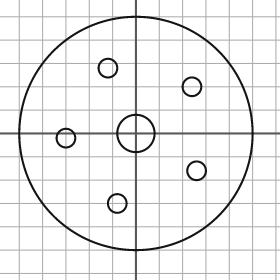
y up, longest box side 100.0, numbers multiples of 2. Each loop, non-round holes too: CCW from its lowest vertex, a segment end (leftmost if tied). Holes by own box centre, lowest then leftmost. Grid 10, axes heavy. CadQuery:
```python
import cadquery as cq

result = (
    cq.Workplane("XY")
    .moveTo(0.0, 0.0)
    .circle(50.0)
    .moveTo(-8.0, -30.0)
    .circle(4.0)
    .moveTo(26.0, -16.0)
    .circle(4.0)
    .moveTo(-30.0, -2.0)
    .circle(4.0)
    .moveTo(0.0, 0.0)
    .circle(8.0)
    .moveTo(24.0, 20.0)
    .circle(4.0)
    .moveTo(-12.0, 28.0)
    .circle(4.0)
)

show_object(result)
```